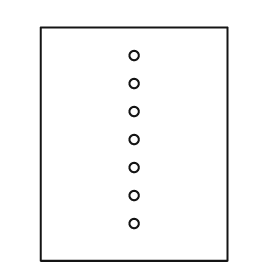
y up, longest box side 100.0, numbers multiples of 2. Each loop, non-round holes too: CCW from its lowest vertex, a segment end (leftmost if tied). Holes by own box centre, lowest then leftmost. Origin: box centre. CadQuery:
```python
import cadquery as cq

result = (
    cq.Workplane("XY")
    .moveTo(-40.0, -50.0)
    .lineTo(40.0, -50.0)
    .lineTo(40.0, 50.0)
    .lineTo(-40.0, 50.0)
    .close()
    .moveTo(0.0, -34.0)
    .circle(2.0)
    .moveTo(0.0, -22.0)
    .circle(2.0)
    .moveTo(0.0, -10.0)
    .circle(2.0)
    .moveTo(0.0, 2.0)
    .circle(2.0)
    .moveTo(0.0, 14.0)
    .circle(2.0)
    .moveTo(0.0, 26.0)
    .circle(2.0)
    .moveTo(0.0, 38.0)
    .circle(2.0)
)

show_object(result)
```